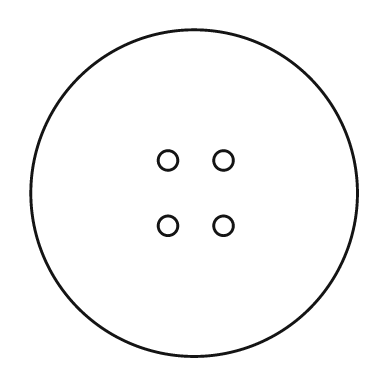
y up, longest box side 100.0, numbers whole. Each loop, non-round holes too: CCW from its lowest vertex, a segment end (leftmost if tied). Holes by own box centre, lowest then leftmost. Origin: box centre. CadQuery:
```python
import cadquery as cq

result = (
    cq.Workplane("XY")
    .moveTo(0.0, 0.0)
    .circle(50.0)
    .moveTo(-8.0, -10.0)
    .circle(3.0)
    .moveTo(9.0, -10.0)
    .circle(3.0)
    .moveTo(-8.0, 10.0)
    .circle(3.0)
    .moveTo(9.0, 10.0)
    .circle(3.0)
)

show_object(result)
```